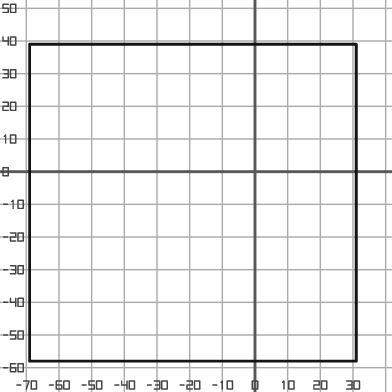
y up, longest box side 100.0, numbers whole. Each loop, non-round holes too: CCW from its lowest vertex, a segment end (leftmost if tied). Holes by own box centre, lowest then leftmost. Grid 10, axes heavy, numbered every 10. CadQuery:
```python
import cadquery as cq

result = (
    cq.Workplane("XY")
    .moveTo(-69.0, -58.0)
    .lineTo(31.0, -58.0)
    .lineTo(31.0, 39.0)
    .lineTo(-69.0, 39.0)
    .close()
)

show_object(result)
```